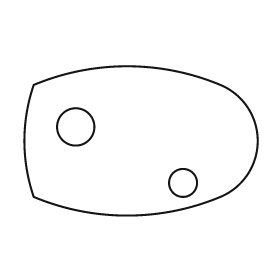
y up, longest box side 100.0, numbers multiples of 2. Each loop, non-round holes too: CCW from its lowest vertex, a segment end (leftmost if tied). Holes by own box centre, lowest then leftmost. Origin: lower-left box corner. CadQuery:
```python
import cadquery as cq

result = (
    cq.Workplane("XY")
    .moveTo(4.0, 8.0)
    .threePointArc((44.0, 0.0), (84.0, 8.0))
    .threePointArc((100.0, 32.0), (84.0, 56.0))
    .threePointArc((44.0, 64.0), (4.0, 56.0))
    .threePointArc((0.0, 32.0), (4.0, 8.0))
    .close()
    .moveTo(68.0, 14.0)
    .circle(6.0)
    .moveTo(22.0, 38.0)
    .circle(8.0)
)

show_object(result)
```